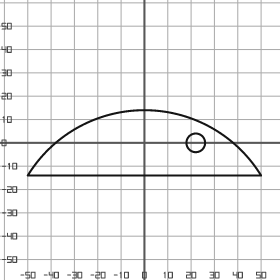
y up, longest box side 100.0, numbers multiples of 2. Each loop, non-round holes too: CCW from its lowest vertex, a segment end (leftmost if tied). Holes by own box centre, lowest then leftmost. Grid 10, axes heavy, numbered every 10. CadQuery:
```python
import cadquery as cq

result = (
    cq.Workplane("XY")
    .moveTo(-50.0, -14.0)
    .lineTo(50.0, -14.0)
    .threePointArc((0.0, 14.0), (-50.0, -14.0))
    .close()
    .moveTo(22.0, 0.0)
    .circle(4.0)
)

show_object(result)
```